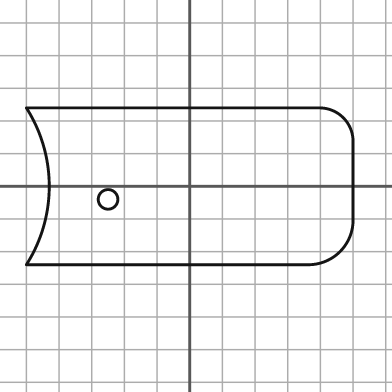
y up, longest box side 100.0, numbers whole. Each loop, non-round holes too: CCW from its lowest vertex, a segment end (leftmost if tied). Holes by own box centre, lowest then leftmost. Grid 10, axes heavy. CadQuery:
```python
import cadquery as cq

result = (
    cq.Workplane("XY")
    .moveTo(-50.0, -24.0)
    .lineTo(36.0, -24.0)
    .threePointArc((46.0, -20.0), (50.0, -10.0))
    .lineTo(50.0, 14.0)
    .threePointArc((47.0, 21.0), (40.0, 24.0))
    .lineTo(-50.0, 24.0)
    .threePointArc((-43.0, 0.0), (-50.0, -24.0))
    .close()
    .moveTo(-25.0, -4.0)
    .circle(3.0)
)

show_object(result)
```